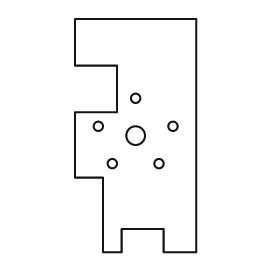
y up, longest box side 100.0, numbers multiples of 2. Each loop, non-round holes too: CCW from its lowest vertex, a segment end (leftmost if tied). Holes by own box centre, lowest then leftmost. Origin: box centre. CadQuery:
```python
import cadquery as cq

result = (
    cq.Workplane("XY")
    .moveTo(-14.0, -50.0)
    .lineTo(-6.0, -50.0)
    .lineTo(-6.0, -40.0)
    .lineTo(12.0, -40.0)
    .lineTo(12.0, -50.0)
    .lineTo(26.0, -50.0)
    .lineTo(26.0, 50.0)
    .lineTo(-26.0, 50.0)
    .lineTo(-26.0, 30.0)
    .lineTo(-8.0, 30.0)
    .lineTo(-8.0, 10.0)
    .lineTo(-26.0, 10.0)
    .lineTo(-26.0, -18.0)
    .lineTo(-14.0, -18.0)
    .close()
    .moveTo(-10.0, -12.0)
    .circle(2.0)
    .moveTo(10.0, -12.0)
    .circle(2.0)
    .moveTo(0.0, 0.0)
    .circle(4.0)
    .moveTo(-16.0, 4.0)
    .circle(2.0)
    .moveTo(16.0, 4.0)
    .circle(2.0)
    .moveTo(0.0, 16.0)
    .circle(2.0)
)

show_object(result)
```